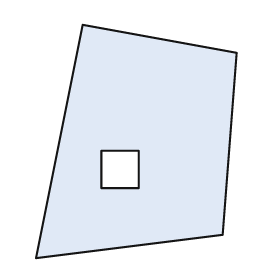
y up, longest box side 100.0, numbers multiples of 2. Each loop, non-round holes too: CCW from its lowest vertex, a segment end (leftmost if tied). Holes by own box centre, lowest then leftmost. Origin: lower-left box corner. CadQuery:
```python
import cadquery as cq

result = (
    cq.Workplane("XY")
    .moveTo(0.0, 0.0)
    .lineTo(80.0, 10.0)
    .lineTo(86.0, 88.0)
    .lineTo(20.0, 100.0)
    .close()
    .moveTo(28.0, 30.0)
    .lineTo(44.0, 30.0)
    .lineTo(44.0, 46.0)
    .lineTo(28.0, 46.0)
    .close()
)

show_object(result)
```